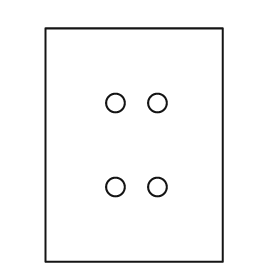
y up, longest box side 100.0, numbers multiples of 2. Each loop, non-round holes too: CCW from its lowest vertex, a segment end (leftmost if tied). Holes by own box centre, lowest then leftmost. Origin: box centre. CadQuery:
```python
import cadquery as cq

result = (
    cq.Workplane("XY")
    .moveTo(-38.0, -50.0)
    .lineTo(38.0, -50.0)
    .lineTo(38.0, 50.0)
    .lineTo(-38.0, 50.0)
    .close()
    .moveTo(-8.0, -18.0)
    .circle(4.0)
    .moveTo(10.0, -18.0)
    .circle(4.0)
    .moveTo(-8.0, 18.0)
    .circle(4.0)
    .moveTo(10.0, 18.0)
    .circle(4.0)
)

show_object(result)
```